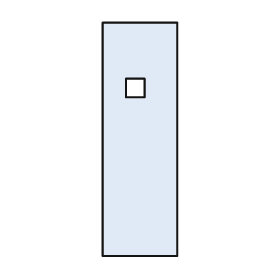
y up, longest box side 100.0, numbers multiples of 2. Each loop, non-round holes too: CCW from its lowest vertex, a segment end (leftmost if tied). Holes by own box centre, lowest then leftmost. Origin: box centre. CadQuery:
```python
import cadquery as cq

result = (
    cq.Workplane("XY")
    .moveTo(-16.0, -50.0)
    .lineTo(16.0, -50.0)
    .lineTo(16.0, 50.0)
    .lineTo(-16.0, 50.0)
    .close()
    .moveTo(-6.0, 18.0)
    .lineTo(2.0, 18.0)
    .lineTo(2.0, 26.0)
    .lineTo(-6.0, 26.0)
    .close()
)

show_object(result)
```